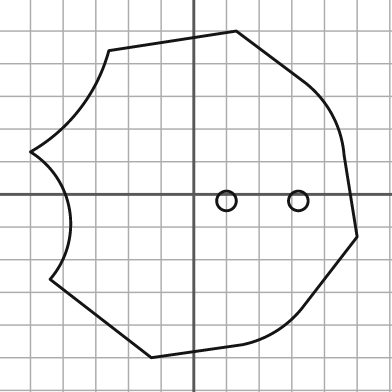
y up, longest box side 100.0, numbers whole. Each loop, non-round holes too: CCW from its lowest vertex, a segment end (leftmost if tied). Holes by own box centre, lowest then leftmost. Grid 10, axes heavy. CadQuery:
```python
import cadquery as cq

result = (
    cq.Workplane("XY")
    .moveTo(-13.0, -50.0)
    .lineTo(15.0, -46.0)
    .threePointArc((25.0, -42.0), (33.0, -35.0))
    .lineTo(50.0, -13.0)
    .lineTo(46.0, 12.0)
    .threePointArc((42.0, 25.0), (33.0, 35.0))
    .lineTo(13.0, 50.0)
    .lineTo(-26.0, 44.0)
    .threePointArc((-35.0, 26.0), (-50.0, 13.0))
    .threePointArc((-38.0, -5.0), (-44.0, -26.0))
    .close()
    .moveTo(10.0, -2.0)
    .circle(3.0)
    .moveTo(32.0, -2.0)
    .circle(3.0)
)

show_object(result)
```